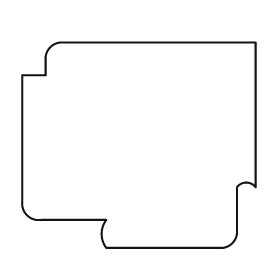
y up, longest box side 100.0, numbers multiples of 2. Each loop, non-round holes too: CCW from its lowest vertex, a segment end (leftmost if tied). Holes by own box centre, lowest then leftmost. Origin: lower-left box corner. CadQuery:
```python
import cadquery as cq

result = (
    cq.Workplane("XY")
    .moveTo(36.0, 0.0)
    .lineTo(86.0, 0.0)
    .threePointArc((90.0, 2.0), (92.0, 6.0))
    .lineTo(92.0, 26.0)
    .threePointArc((96.0, 28.0), (100.0, 26.0))
    .lineTo(100.0, 88.0)
    .lineTo(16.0, 88.0)
    .threePointArc((12.0, 86.0), (10.0, 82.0))
    .lineTo(10.0, 74.0)
    .lineTo(0.0, 74.0)
    .lineTo(0.0, 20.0)
    .threePointArc((2.0, 14.0), (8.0, 12.0))
    .lineTo(36.0, 12.0)
    .threePointArc((34.0, 6.0), (36.0, 0.0))
    .close()
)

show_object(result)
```